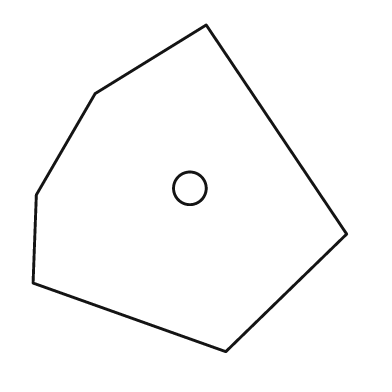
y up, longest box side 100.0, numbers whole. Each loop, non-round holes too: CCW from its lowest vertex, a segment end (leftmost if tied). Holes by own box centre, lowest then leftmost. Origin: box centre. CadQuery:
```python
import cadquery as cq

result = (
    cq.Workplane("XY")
    .moveTo(11.0, -50.0)
    .lineTo(48.0, -14.0)
    .lineTo(5.0, 50.0)
    .lineTo(-29.0, 29.0)
    .lineTo(-47.0, -2.0)
    .lineTo(-48.0, -29.0)
    .close()
    .moveTo(0.0, 0.0)
    .circle(5.0)
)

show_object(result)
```